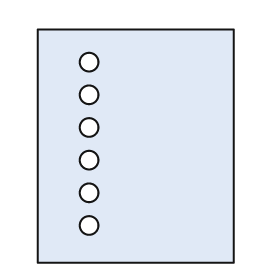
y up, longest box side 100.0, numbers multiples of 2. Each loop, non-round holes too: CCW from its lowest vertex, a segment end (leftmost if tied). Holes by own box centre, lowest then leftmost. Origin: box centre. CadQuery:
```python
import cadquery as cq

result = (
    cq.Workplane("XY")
    .moveTo(-42.0, -50.0)
    .lineTo(42.0, -50.0)
    .lineTo(42.0, 50.0)
    .lineTo(-42.0, 50.0)
    .close()
    .moveTo(-20.0, -34.0)
    .circle(4.0)
    .moveTo(-20.0, -20.0)
    .circle(4.0)
    .moveTo(-20.0, -6.0)
    .circle(4.0)
    .moveTo(-20.0, 8.0)
    .circle(4.0)
    .moveTo(-20.0, 22.0)
    .circle(4.0)
    .moveTo(-20.0, 36.0)
    .circle(4.0)
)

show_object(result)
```